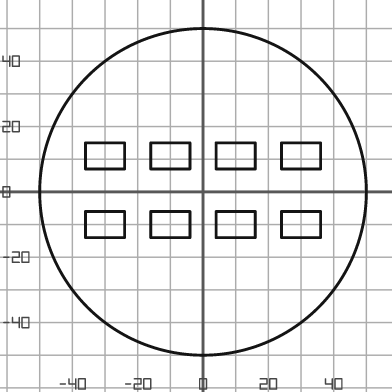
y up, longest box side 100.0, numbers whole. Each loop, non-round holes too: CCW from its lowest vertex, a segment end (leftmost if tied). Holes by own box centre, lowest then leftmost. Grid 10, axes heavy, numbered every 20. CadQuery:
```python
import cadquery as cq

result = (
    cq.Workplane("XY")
    .moveTo(0.0, 0.0)
    .circle(50.0)
    .moveTo(-36.0, -14.0)
    .lineTo(-24.0, -14.0)
    .lineTo(-24.0, -6.0)
    .lineTo(-36.0, -6.0)
    .close()
    .moveTo(-16.0, -14.0)
    .lineTo(-4.0, -14.0)
    .lineTo(-4.0, -6.0)
    .lineTo(-16.0, -6.0)
    .close()
    .moveTo(4.0, -14.0)
    .lineTo(16.0, -14.0)
    .lineTo(16.0, -6.0)
    .lineTo(4.0, -6.0)
    .close()
    .moveTo(24.0, -14.0)
    .lineTo(36.0, -14.0)
    .lineTo(36.0, -6.0)
    .lineTo(24.0, -6.0)
    .close()
    .moveTo(-36.0, 7.0)
    .lineTo(-24.0, 7.0)
    .lineTo(-24.0, 15.0)
    .lineTo(-36.0, 15.0)
    .close()
    .moveTo(-16.0, 7.0)
    .lineTo(-4.0, 7.0)
    .lineTo(-4.0, 15.0)
    .lineTo(-16.0, 15.0)
    .close()
    .moveTo(4.0, 7.0)
    .lineTo(16.0, 7.0)
    .lineTo(16.0, 15.0)
    .lineTo(4.0, 15.0)
    .close()
    .moveTo(24.0, 7.0)
    .lineTo(36.0, 7.0)
    .lineTo(36.0, 15.0)
    .lineTo(24.0, 15.0)
    .close()
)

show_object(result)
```